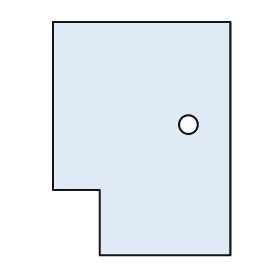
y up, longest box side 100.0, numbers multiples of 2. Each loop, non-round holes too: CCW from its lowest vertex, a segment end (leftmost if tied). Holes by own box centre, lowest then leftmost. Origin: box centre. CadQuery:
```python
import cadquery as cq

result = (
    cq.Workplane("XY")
    .moveTo(-18.0, -50.0)
    .lineTo(38.0, -50.0)
    .lineTo(38.0, 50.0)
    .lineTo(-38.0, 50.0)
    .lineTo(-38.0, -22.0)
    .lineTo(-18.0, -22.0)
    .close()
    .moveTo(20.0, 6.0)
    .circle(4.0)
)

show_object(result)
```